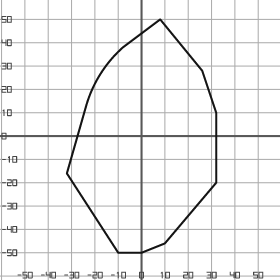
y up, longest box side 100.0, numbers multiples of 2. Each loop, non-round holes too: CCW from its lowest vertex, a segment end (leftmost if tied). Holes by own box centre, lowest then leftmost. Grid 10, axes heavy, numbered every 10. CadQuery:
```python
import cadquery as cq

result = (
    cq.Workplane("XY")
    .moveTo(-10.0, -50.0)
    .lineTo(0.0, -50.0)
    .lineTo(10.0, -46.0)
    .lineTo(32.0, -20.0)
    .lineTo(32.0, 10.0)
    .lineTo(26.0, 28.0)
    .lineTo(8.0, 50.0)
    .lineTo(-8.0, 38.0)
    .threePointArc((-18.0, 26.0), (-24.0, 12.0))
    .lineTo(-32.0, -16.0)
    .close()
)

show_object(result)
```